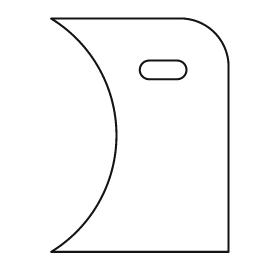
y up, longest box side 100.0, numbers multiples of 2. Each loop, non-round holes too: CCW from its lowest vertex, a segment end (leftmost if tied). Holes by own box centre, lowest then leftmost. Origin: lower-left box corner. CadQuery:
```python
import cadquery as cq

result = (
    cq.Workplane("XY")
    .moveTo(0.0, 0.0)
    .lineTo(76.0, 0.0)
    .lineTo(76.0, 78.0)
    .threePointArc((70.0, 94.0), (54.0, 100.0))
    .lineTo(0.0, 100.0)
    .threePointArc((28.0, 50.0), (0.0, 0.0))
    .close()
    .moveTo(42.0, 74.0)
    .lineTo(54.0, 74.0)
    .threePointArc((58.0, 78.0), (54.0, 82.0))
    .lineTo(42.0, 82.0)
    .threePointArc((38.0, 78.0), (42.0, 74.0))
    .close()
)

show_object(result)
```